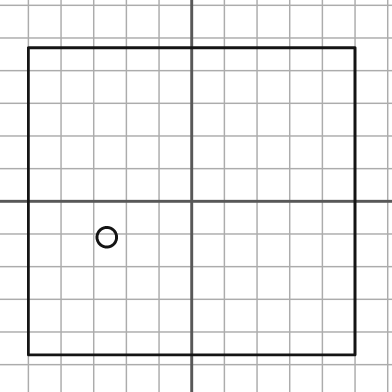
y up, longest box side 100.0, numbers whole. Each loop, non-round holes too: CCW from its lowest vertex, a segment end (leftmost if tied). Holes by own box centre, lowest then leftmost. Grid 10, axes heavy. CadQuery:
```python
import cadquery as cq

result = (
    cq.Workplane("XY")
    .moveTo(-50.0, -47.0)
    .lineTo(50.0, -47.0)
    .lineTo(50.0, 47.0)
    .lineTo(-50.0, 47.0)
    .close()
    .moveTo(-26.0, -11.0)
    .circle(3.0)
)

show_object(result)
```